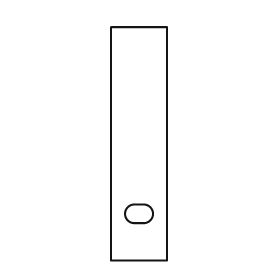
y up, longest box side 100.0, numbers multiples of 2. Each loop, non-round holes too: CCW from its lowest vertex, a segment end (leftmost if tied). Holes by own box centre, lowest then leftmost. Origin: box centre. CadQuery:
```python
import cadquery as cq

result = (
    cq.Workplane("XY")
    .moveTo(-12.0, -50.0)
    .lineTo(12.0, -50.0)
    .lineTo(12.0, 50.0)
    .lineTo(-12.0, 50.0)
    .close()
    .moveTo(-2.0, -34.0)
    .lineTo(2.0, -34.0)
    .threePointArc((6.0, -30.0), (2.0, -26.0))
    .lineTo(-2.0, -26.0)
    .threePointArc((-6.0, -30.0), (-2.0, -34.0))
    .close()
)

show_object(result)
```